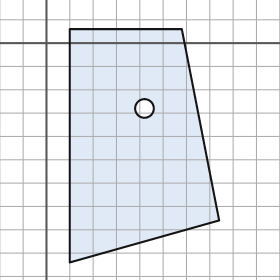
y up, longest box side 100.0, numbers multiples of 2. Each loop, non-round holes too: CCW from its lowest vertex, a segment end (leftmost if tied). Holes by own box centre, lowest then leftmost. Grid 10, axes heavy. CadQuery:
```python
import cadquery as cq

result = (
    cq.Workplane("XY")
    .moveTo(10.0, -94.0)
    .lineTo(74.0, -76.0)
    .lineTo(58.0, 6.0)
    .lineTo(10.0, 6.0)
    .close()
    .moveTo(42.0, -28.0)
    .circle(4.0)
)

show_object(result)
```